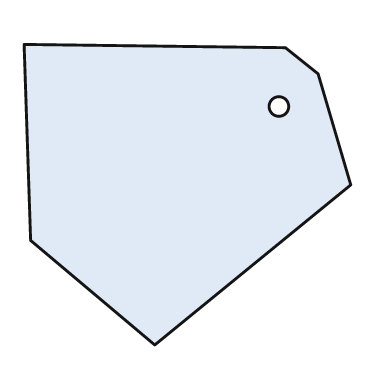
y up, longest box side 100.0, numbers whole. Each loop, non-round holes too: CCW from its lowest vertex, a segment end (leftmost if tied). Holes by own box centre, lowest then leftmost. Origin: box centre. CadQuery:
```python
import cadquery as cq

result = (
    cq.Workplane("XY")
    .moveTo(-10.0, -46.0)
    .lineTo(50.0, 3.0)
    .lineTo(40.0, 37.0)
    .lineTo(30.0, 45.0)
    .lineTo(-50.0, 46.0)
    .lineTo(-48.0, -14.0)
    .close()
    .moveTo(28.0, 27.0)
    .circle(3.0)
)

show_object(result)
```